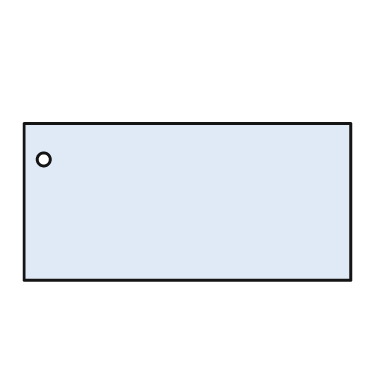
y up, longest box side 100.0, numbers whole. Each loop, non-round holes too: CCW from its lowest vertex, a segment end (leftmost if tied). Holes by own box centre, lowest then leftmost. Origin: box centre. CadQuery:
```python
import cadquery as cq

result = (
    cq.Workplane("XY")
    .moveTo(-50.0, -24.0)
    .lineTo(50.0, -24.0)
    .lineTo(50.0, 24.0)
    .lineTo(-50.0, 24.0)
    .close()
    .moveTo(-44.0, 13.0)
    .circle(2.0)
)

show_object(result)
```